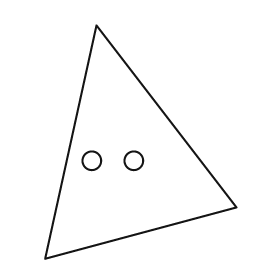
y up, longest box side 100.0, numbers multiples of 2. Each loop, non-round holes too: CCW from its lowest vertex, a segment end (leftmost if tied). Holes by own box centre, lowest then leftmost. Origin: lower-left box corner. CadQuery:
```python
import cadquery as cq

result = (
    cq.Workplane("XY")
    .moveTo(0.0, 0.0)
    .lineTo(82.0, 22.0)
    .lineTo(22.0, 100.0)
    .close()
    .moveTo(20.0, 42.0)
    .circle(4.0)
    .moveTo(38.0, 42.0)
    .circle(4.0)
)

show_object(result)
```